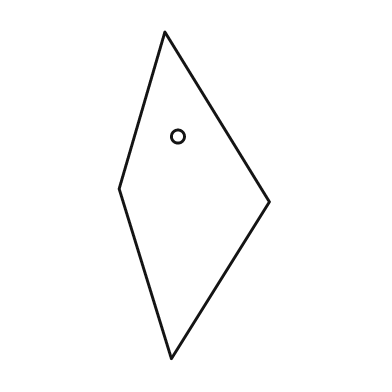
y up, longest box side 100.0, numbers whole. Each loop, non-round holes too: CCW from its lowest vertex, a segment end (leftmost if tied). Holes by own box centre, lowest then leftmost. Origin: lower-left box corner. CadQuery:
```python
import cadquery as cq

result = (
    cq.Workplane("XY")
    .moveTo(16.0, 0.0)
    .lineTo(46.0, 48.0)
    .lineTo(14.0, 100.0)
    .lineTo(0.0, 52.0)
    .close()
    .moveTo(18.0, 68.0)
    .circle(2.0)
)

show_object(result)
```